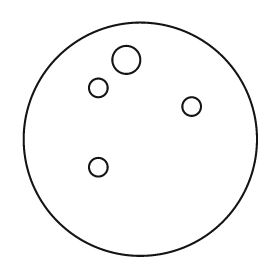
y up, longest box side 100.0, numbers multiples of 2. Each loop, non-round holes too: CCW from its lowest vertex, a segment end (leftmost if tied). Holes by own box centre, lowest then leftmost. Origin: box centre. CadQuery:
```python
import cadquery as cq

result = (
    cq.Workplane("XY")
    .moveTo(0.0, 0.0)
    .circle(50.0)
    .moveTo(-18.0, -12.0)
    .circle(4.0)
    .moveTo(22.0, 14.0)
    .circle(4.0)
    .moveTo(-18.0, 22.0)
    .circle(4.0)
    .moveTo(-6.0, 34.0)
    .circle(6.0)
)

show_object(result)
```